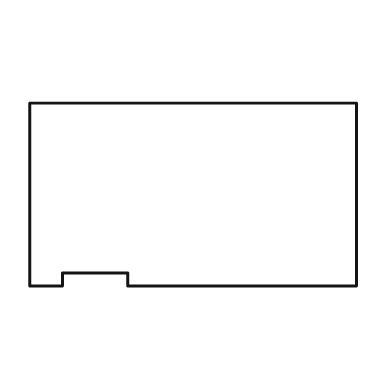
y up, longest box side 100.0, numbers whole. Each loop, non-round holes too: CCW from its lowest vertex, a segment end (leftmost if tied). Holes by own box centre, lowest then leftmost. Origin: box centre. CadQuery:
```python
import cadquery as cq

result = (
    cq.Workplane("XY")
    .moveTo(-50.0, -28.0)
    .lineTo(-40.0, -28.0)
    .lineTo(-40.0, -24.0)
    .lineTo(-20.0, -24.0)
    .lineTo(-20.0, -28.0)
    .lineTo(50.0, -28.0)
    .lineTo(50.0, 28.0)
    .lineTo(-50.0, 28.0)
    .close()
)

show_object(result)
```